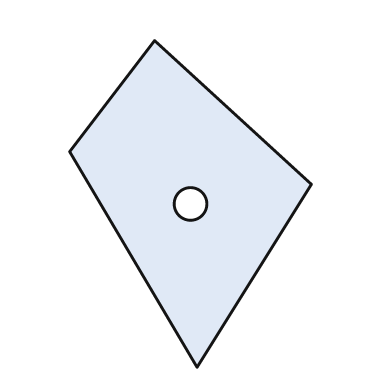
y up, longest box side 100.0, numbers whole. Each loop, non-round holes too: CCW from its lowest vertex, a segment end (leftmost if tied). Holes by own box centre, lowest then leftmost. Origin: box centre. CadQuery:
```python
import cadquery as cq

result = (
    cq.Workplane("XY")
    .moveTo(2.0, -50.0)
    .lineTo(37.0, 6.0)
    .lineTo(-11.0, 50.0)
    .lineTo(-37.0, 16.0)
    .close()
    .moveTo(0.0, 0.0)
    .circle(5.0)
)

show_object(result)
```